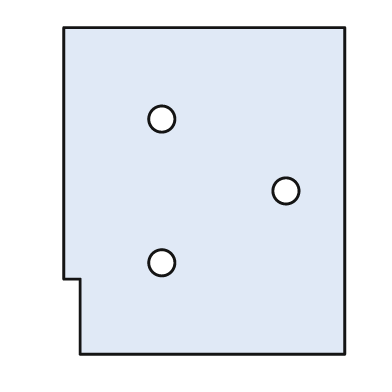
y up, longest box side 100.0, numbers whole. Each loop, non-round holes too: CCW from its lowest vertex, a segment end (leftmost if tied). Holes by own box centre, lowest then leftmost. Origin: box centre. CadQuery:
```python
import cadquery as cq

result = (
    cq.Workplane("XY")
    .moveTo(-38.0, -50.0)
    .lineTo(43.0, -50.0)
    .lineTo(43.0, 50.0)
    .lineTo(-43.0, 50.0)
    .lineTo(-43.0, -27.0)
    .lineTo(-38.0, -27.0)
    .close()
    .moveTo(-13.0, -22.0)
    .circle(4.0)
    .moveTo(25.0, 0.0)
    .circle(4.0)
    .moveTo(-13.0, 22.0)
    .circle(4.0)
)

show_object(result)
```